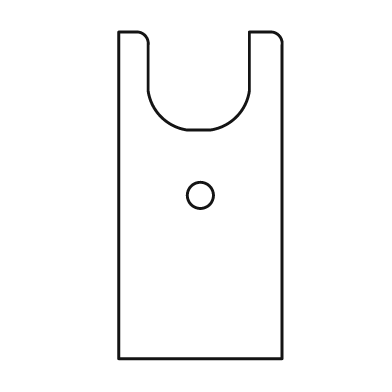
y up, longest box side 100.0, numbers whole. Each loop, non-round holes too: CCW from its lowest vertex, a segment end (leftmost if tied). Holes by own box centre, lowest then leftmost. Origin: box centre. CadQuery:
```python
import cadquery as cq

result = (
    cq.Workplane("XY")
    .moveTo(-25.0, -50.0)
    .lineTo(25.0, -50.0)
    .lineTo(25.0, 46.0)
    .threePointArc((24.0, 49.0), (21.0, 50.0))
    .lineTo(15.0, 50.0)
    .lineTo(15.0, 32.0)
    .threePointArc((11.0, 24.0), (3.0, 20.0))
    .lineTo(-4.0, 20.0)
    .threePointArc((-12.0, 24.0), (-16.0, 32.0))
    .lineTo(-16.0, 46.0)
    .threePointArc((-17.0, 49.0), (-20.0, 50.0))
    .lineTo(-25.0, 50.0)
    .close()
    .moveTo(0.0, 0.0)
    .circle(4.0)
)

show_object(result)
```